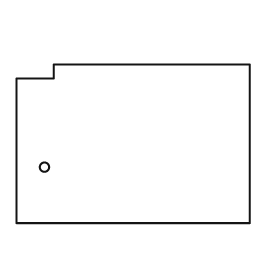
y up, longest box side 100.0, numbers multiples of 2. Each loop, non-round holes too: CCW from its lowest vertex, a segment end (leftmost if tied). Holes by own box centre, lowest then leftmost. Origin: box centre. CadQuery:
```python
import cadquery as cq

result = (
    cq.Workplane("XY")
    .moveTo(-50.0, -34.0)
    .lineTo(50.0, -34.0)
    .lineTo(50.0, 34.0)
    .lineTo(-34.0, 34.0)
    .lineTo(-34.0, 28.0)
    .lineTo(-50.0, 28.0)
    .close()
    .moveTo(-38.0, -10.0)
    .circle(2.0)
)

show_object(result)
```